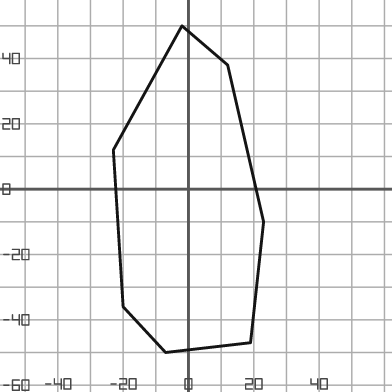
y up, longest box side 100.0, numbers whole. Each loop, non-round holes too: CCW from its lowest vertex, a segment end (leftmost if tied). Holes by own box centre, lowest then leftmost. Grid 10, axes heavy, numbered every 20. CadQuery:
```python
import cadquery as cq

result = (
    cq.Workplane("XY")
    .moveTo(-7.0, -50.0)
    .lineTo(19.0, -47.0)
    .lineTo(23.0, -10.0)
    .lineTo(12.0, 38.0)
    .lineTo(-2.0, 50.0)
    .lineTo(-23.0, 12.0)
    .lineTo(-20.0, -36.0)
    .close()
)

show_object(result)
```